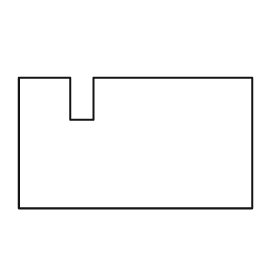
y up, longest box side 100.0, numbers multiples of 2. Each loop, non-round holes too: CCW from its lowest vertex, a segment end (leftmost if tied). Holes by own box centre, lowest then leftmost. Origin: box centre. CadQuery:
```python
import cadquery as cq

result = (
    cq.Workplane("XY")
    .moveTo(-50.0, -28.0)
    .lineTo(50.0, -28.0)
    .lineTo(50.0, 28.0)
    .lineTo(-18.0, 28.0)
    .lineTo(-18.0, 10.0)
    .lineTo(-28.0, 10.0)
    .lineTo(-28.0, 28.0)
    .lineTo(-50.0, 28.0)
    .close()
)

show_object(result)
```